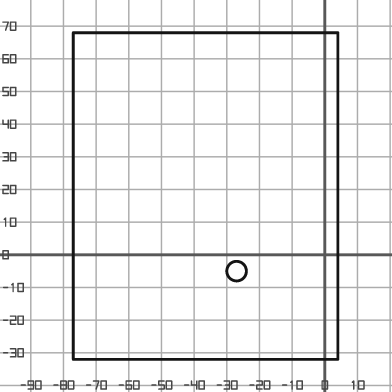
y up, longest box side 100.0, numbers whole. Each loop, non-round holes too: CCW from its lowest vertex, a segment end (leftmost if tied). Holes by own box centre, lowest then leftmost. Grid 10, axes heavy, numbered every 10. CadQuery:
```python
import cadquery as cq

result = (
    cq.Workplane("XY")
    .moveTo(-77.0, -32.0)
    .lineTo(4.0, -32.0)
    .lineTo(4.0, 68.0)
    .lineTo(-77.0, 68.0)
    .close()
    .moveTo(-27.0, -5.0)
    .circle(3.0)
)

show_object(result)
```